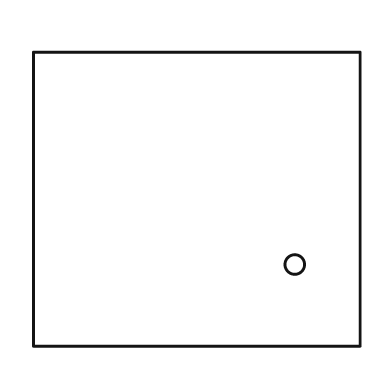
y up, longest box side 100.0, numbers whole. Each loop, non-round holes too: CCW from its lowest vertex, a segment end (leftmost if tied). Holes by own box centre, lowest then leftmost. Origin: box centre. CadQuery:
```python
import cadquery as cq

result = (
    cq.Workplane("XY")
    .moveTo(-50.0, -45.0)
    .lineTo(50.0, -45.0)
    .lineTo(50.0, 45.0)
    .lineTo(-50.0, 45.0)
    .close()
    .moveTo(30.0, -20.0)
    .circle(3.0)
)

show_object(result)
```